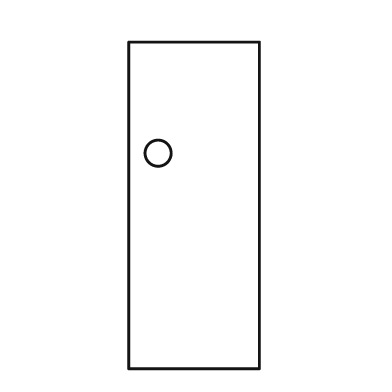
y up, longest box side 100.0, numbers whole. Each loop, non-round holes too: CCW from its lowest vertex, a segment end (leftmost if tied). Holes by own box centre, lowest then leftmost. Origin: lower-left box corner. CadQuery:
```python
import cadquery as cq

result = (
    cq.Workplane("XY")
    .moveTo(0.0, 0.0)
    .lineTo(40.0, 0.0)
    .lineTo(40.0, 100.0)
    .lineTo(0.0, 100.0)
    .close()
    .moveTo(9.0, 66.0)
    .circle(4.0)
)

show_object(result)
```